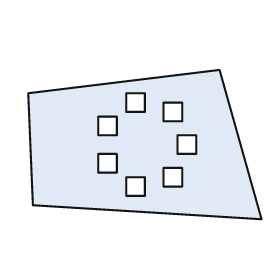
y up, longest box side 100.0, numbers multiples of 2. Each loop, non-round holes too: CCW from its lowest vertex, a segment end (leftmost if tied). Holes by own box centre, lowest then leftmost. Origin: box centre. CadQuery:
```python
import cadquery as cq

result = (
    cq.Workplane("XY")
    .moveTo(50.0, -32.0)
    .lineTo(32.0, 32.0)
    .lineTo(-50.0, 22.0)
    .lineTo(-48.0, -26.0)
    .close()
    .moveTo(-8.0, -22.0)
    .lineTo(0.0, -22.0)
    .lineTo(0.0, -14.0)
    .lineTo(-8.0, -14.0)
    .close()
    .moveTo(8.0, -18.0)
    .lineTo(16.0, -18.0)
    .lineTo(16.0, -10.0)
    .lineTo(8.0, -10.0)
    .close()
    .moveTo(-20.0, -12.0)
    .lineTo(-12.0, -12.0)
    .lineTo(-12.0, -4.0)
    .lineTo(-20.0, -4.0)
    .close()
    .moveTo(14.0, -4.0)
    .lineTo(22.0, -4.0)
    .lineTo(22.0, 4.0)
    .lineTo(14.0, 4.0)
    .close()
    .moveTo(-20.0, 4.0)
    .lineTo(-12.0, 4.0)
    .lineTo(-12.0, 12.0)
    .lineTo(-20.0, 12.0)
    .close()
    .moveTo(8.0, 10.0)
    .lineTo(16.0, 10.0)
    .lineTo(16.0, 18.0)
    .lineTo(8.0, 18.0)
    .close()
    .moveTo(-8.0, 14.0)
    .lineTo(0.0, 14.0)
    .lineTo(0.0, 22.0)
    .lineTo(-8.0, 22.0)
    .close()
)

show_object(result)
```